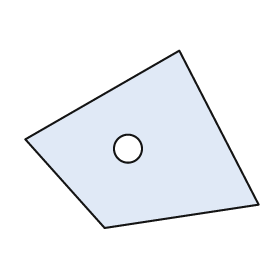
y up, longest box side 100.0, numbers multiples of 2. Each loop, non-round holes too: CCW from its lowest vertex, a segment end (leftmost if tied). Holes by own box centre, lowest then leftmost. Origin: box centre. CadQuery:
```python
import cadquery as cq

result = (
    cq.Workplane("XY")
    .moveTo(-16.0, -38.0)
    .lineTo(50.0, -28.0)
    .lineTo(16.0, 38.0)
    .lineTo(-50.0, 0.0)
    .close()
    .moveTo(-6.0, -4.0)
    .circle(6.0)
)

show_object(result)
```